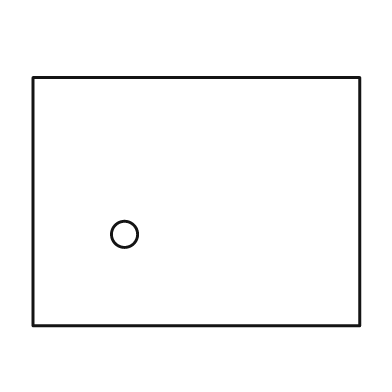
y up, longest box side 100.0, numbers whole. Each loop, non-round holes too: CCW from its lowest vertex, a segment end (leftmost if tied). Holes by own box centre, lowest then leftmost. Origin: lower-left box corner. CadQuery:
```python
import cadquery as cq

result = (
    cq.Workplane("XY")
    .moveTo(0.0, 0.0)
    .lineTo(100.0, 0.0)
    .lineTo(100.0, 76.0)
    .lineTo(0.0, 76.0)
    .close()
    .moveTo(28.0, 28.0)
    .circle(4.0)
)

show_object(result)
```